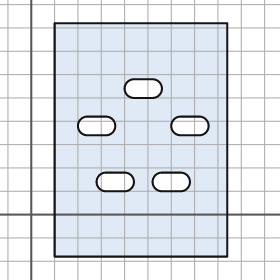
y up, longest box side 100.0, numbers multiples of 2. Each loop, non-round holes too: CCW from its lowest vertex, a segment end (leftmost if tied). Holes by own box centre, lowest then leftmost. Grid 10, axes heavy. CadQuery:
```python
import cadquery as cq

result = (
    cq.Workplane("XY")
    .moveTo(10.0, -18.0)
    .lineTo(84.0, -18.0)
    .lineTo(84.0, 82.0)
    .lineTo(10.0, 82.0)
    .close()
    .moveTo(32.0, 10.0)
    .lineTo(40.0, 10.0)
    .threePointArc((44.0, 14.0), (40.0, 18.0))
    .lineTo(32.0, 18.0)
    .threePointArc((28.0, 14.0), (32.0, 10.0))
    .close()
    .moveTo(56.0, 10.0)
    .lineTo(64.0, 10.0)
    .threePointArc((68.0, 14.0), (64.0, 18.0))
    .lineTo(56.0, 18.0)
    .threePointArc((52.0, 14.0), (56.0, 10.0))
    .close()
    .moveTo(24.0, 34.0)
    .lineTo(32.0, 34.0)
    .threePointArc((36.0, 38.0), (32.0, 42.0))
    .lineTo(24.0, 42.0)
    .threePointArc((20.0, 38.0), (24.0, 34.0))
    .close()
    .moveTo(64.0, 34.0)
    .lineTo(72.0, 34.0)
    .threePointArc((76.0, 38.0), (72.0, 42.0))
    .lineTo(64.0, 42.0)
    .threePointArc((60.0, 38.0), (64.0, 34.0))
    .close()
    .moveTo(44.0, 50.0)
    .lineTo(52.0, 50.0)
    .threePointArc((56.0, 54.0), (52.0, 58.0))
    .lineTo(44.0, 58.0)
    .threePointArc((40.0, 54.0), (44.0, 50.0))
    .close()
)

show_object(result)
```